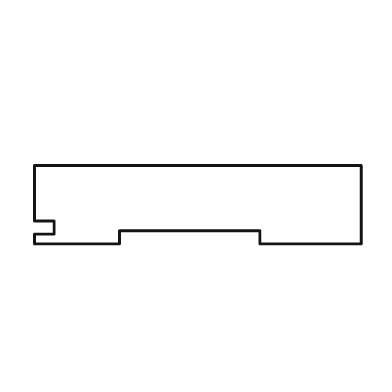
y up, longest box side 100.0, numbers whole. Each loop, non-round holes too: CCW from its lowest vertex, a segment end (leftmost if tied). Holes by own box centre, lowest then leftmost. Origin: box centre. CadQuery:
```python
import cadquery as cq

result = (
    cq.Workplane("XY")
    .moveTo(-50.0, -12.0)
    .lineTo(-24.0, -12.0)
    .lineTo(-24.0, -8.0)
    .lineTo(19.0, -8.0)
    .lineTo(19.0, -12.0)
    .lineTo(50.0, -12.0)
    .lineTo(50.0, 12.0)
    .lineTo(-50.0, 12.0)
    .lineTo(-50.0, -5.0)
    .lineTo(-44.0, -5.0)
    .lineTo(-44.0, -9.0)
    .lineTo(-50.0, -9.0)
    .close()
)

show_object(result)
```